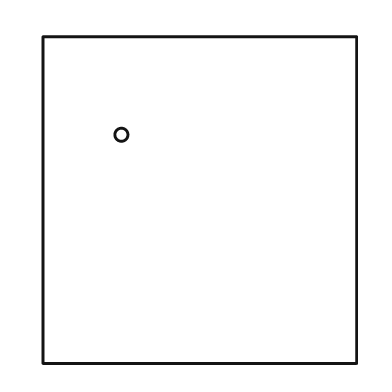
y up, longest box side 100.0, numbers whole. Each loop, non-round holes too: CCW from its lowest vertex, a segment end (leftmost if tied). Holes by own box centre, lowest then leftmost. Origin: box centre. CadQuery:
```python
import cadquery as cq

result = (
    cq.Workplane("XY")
    .moveTo(-48.0, -50.0)
    .lineTo(48.0, -50.0)
    .lineTo(48.0, 50.0)
    .lineTo(-48.0, 50.0)
    .close()
    .moveTo(-24.0, 20.0)
    .circle(2.0)
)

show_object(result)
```